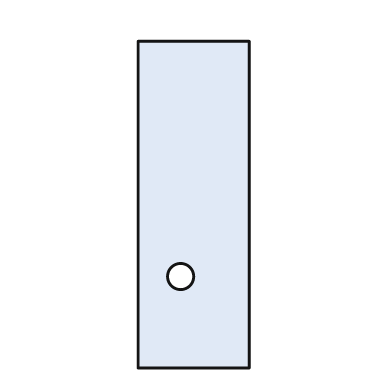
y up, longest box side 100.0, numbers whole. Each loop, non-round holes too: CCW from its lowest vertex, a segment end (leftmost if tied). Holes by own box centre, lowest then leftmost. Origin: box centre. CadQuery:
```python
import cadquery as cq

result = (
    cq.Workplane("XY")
    .moveTo(-17.0, -50.0)
    .lineTo(17.0, -50.0)
    .lineTo(17.0, 50.0)
    .lineTo(-17.0, 50.0)
    .close()
    .moveTo(-4.0, -22.0)
    .circle(4.0)
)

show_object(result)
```